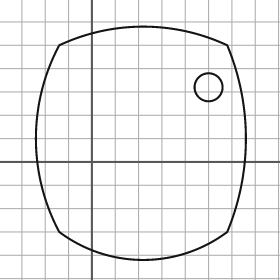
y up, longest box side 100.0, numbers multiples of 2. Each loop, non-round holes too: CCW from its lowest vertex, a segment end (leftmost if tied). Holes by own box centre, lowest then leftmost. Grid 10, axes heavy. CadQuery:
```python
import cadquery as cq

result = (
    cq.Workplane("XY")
    .moveTo(-14.0, -30.0)
    .threePointArc((22.0, -42.0), (58.0, -30.0))
    .threePointArc((66.0, 10.0), (58.0, 50.0))
    .threePointArc((22.0, 58.0), (-14.0, 50.0))
    .threePointArc((-24.0, 10.0), (-14.0, -30.0))
    .close()
    .moveTo(50.0, 32.0)
    .circle(6.0)
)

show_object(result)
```